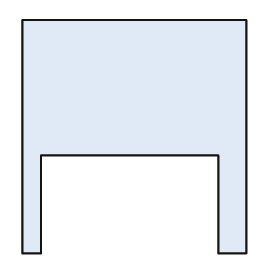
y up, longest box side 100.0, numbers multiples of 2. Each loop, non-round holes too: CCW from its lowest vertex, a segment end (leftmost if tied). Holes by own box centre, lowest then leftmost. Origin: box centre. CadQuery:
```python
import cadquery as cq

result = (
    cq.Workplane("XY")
    .moveTo(-48.0, -50.0)
    .lineTo(-40.0, -50.0)
    .lineTo(-40.0, -8.0)
    .lineTo(36.0, -8.0)
    .lineTo(36.0, -50.0)
    .lineTo(48.0, -50.0)
    .lineTo(48.0, 50.0)
    .lineTo(-48.0, 50.0)
    .close()
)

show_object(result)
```